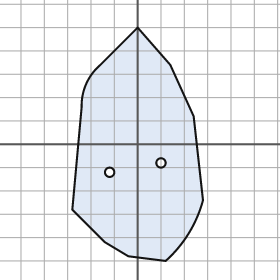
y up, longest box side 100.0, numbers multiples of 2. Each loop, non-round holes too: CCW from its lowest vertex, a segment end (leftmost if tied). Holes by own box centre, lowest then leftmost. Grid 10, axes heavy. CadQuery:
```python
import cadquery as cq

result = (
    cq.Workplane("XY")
    .moveTo(12.0, -50.0)
    .threePointArc((22.0, -38.0), (28.0, -24.0))
    .lineTo(24.0, 12.0)
    .lineTo(14.0, 34.0)
    .lineTo(0.0, 50.0)
    .lineTo(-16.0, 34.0)
    .threePointArc((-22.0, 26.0), (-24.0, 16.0))
    .lineTo(-28.0, -28.0)
    .lineTo(-14.0, -42.0)
    .lineTo(-4.0, -48.0)
    .close()
    .moveTo(-12.0, -12.0)
    .circle(2.0)
    .moveTo(10.0, -8.0)
    .circle(2.0)
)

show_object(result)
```